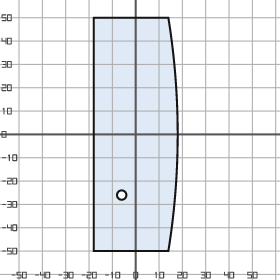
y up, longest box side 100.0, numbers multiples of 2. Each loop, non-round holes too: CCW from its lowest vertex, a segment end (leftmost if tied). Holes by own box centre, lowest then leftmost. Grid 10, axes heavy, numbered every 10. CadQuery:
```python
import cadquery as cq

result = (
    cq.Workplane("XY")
    .moveTo(-18.0, -50.0)
    .lineTo(14.0, -50.0)
    .threePointArc((18.0, 0.0), (14.0, 50.0))
    .lineTo(-18.0, 50.0)
    .close()
    .moveTo(-6.0, -26.0)
    .circle(2.0)
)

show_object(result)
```